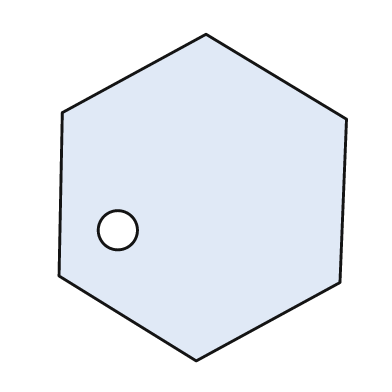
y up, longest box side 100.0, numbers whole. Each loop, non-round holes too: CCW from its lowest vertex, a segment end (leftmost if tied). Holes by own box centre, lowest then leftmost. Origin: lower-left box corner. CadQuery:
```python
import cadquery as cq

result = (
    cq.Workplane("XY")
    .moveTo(42.0, 0.0)
    .lineTo(86.0, 24.0)
    .lineTo(88.0, 74.0)
    .lineTo(45.0, 100.0)
    .lineTo(1.0, 76.0)
    .lineTo(0.0, 26.0)
    .close()
    .moveTo(18.0, 40.0)
    .circle(6.0)
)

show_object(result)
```